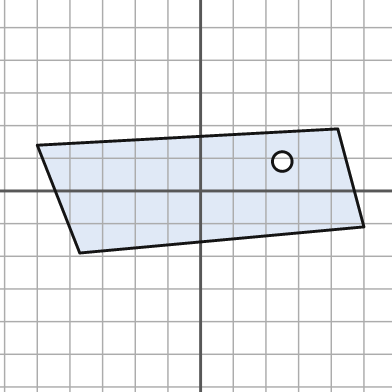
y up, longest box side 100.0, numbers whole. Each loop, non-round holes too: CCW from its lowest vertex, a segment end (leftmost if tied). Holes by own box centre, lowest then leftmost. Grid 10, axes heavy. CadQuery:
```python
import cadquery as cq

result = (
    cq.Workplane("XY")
    .moveTo(-37.0, -19.0)
    .lineTo(50.0, -11.0)
    .lineTo(42.0, 19.0)
    .lineTo(-50.0, 14.0)
    .close()
    .moveTo(25.0, 9.0)
    .circle(3.0)
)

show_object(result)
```